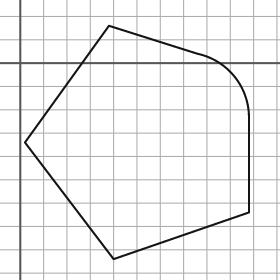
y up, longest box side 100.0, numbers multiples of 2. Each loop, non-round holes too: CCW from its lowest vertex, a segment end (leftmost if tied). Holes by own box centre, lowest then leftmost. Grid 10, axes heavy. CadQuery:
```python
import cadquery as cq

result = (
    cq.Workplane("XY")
    .moveTo(40.0, -84.0)
    .lineTo(98.0, -64.0)
    .lineTo(98.0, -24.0)
    .threePointArc((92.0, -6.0), (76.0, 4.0))
    .lineTo(38.0, 16.0)
    .lineTo(2.0, -34.0)
    .close()
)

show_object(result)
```